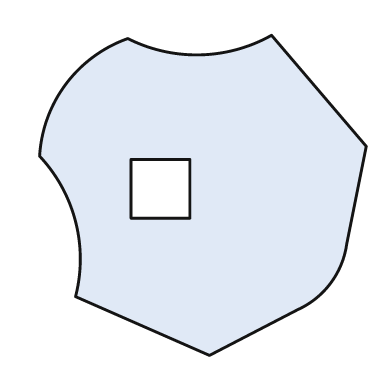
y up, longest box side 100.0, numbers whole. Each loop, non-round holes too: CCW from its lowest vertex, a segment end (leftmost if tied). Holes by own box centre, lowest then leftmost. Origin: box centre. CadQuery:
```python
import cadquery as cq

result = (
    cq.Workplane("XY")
    .moveTo(2.0, -49.0)
    .lineTo(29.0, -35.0)
    .threePointArc((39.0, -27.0), (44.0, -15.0))
    .lineTo(50.0, 15.0)
    .lineTo(21.0, 49.0)
    .threePointArc((-1.0, 43.0), (-23.0, 48.0))
    .threePointArc((-42.0, 34.0), (-50.0, 12.0))
    .threePointArc((-39.0, -8.0), (-39.0, -31.0))
    .close()
    .moveTo(-22.0, -7.0)
    .lineTo(-4.0, -7.0)
    .lineTo(-4.0, 11.0)
    .lineTo(-22.0, 11.0)
    .close()
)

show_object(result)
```